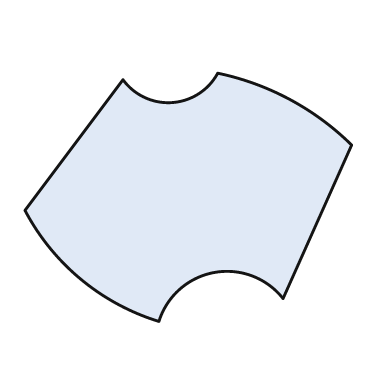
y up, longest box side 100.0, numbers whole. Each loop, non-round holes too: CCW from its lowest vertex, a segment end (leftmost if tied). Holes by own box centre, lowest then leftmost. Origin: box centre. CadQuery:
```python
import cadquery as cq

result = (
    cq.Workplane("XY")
    .moveTo(-9.0, -38.0)
    .threePointArc((8.0, -23.0), (29.0, -31.0))
    .lineTo(50.0, 16.0)
    .threePointArc((31.0, 30.0), (9.0, 38.0))
    .threePointArc((-5.0, 29.0), (-20.0, 36.0))
    .lineTo(-50.0, -4.0)
    .threePointArc((-33.0, -25.0), (-9.0, -38.0))
    .close()
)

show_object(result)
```